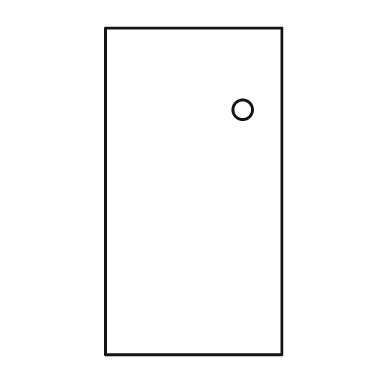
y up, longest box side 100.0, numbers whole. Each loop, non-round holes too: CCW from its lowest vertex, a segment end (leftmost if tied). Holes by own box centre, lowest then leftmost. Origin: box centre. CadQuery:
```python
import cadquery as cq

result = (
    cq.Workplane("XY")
    .moveTo(-27.0, -50.0)
    .lineTo(27.0, -50.0)
    .lineTo(27.0, 50.0)
    .lineTo(-27.0, 50.0)
    .close()
    .moveTo(15.0, 25.0)
    .circle(3.0)
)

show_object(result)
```